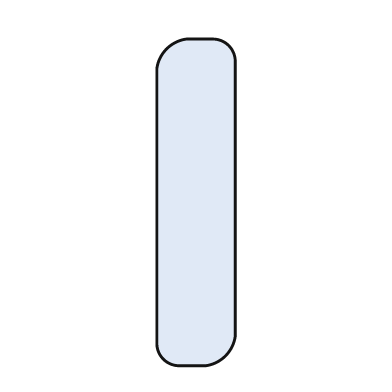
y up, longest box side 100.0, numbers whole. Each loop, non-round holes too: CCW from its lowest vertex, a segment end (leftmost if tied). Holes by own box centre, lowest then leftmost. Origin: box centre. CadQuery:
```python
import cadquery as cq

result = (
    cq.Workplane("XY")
    .moveTo(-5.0, -50.0)
    .lineTo(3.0, -50.0)
    .threePointArc((9.0, -47.0), (12.0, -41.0))
    .lineTo(12.0, 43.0)
    .threePointArc((10.0, 48.0), (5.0, 50.0))
    .lineTo(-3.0, 50.0)
    .threePointArc((-9.0, 47.0), (-12.0, 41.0))
    .lineTo(-12.0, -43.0)
    .threePointArc((-10.0, -48.0), (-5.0, -50.0))
    .close()
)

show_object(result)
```